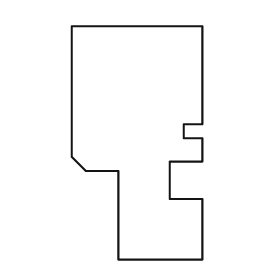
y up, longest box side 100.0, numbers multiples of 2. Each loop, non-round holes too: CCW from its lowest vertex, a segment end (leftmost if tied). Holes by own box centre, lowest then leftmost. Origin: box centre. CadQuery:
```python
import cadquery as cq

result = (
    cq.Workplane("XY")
    .moveTo(-8.0, -50.0)
    .lineTo(28.0, -50.0)
    .lineTo(28.0, -24.0)
    .lineTo(14.0, -24.0)
    .lineTo(14.0, -8.0)
    .lineTo(28.0, -8.0)
    .lineTo(28.0, 2.0)
    .lineTo(20.0, 2.0)
    .lineTo(20.0, 8.0)
    .lineTo(28.0, 8.0)
    .lineTo(28.0, 50.0)
    .lineTo(-28.0, 50.0)
    .lineTo(-28.0, -6.0)
    .lineTo(-22.0, -12.0)
    .lineTo(-8.0, -12.0)
    .close()
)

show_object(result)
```